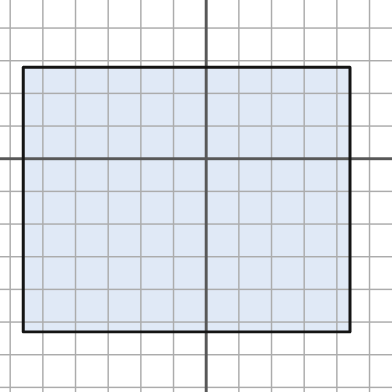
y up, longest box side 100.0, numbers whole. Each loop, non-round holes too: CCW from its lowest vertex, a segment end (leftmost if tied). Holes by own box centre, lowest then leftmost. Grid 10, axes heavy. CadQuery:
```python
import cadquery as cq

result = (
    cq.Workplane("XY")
    .moveTo(-56.0, -53.0)
    .lineTo(44.0, -53.0)
    .lineTo(44.0, 28.0)
    .lineTo(-56.0, 28.0)
    .close()
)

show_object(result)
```